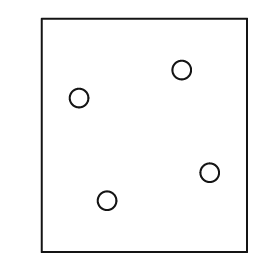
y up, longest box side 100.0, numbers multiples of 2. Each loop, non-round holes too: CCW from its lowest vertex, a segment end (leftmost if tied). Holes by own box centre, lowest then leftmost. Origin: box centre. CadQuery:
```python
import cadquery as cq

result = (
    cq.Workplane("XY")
    .moveTo(-44.0, -50.0)
    .lineTo(44.0, -50.0)
    .lineTo(44.0, 50.0)
    .lineTo(-44.0, 50.0)
    .close()
    .moveTo(-16.0, -28.0)
    .circle(4.0)
    .moveTo(28.0, -16.0)
    .circle(4.0)
    .moveTo(-28.0, 16.0)
    .circle(4.0)
    .moveTo(16.0, 28.0)
    .circle(4.0)
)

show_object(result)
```